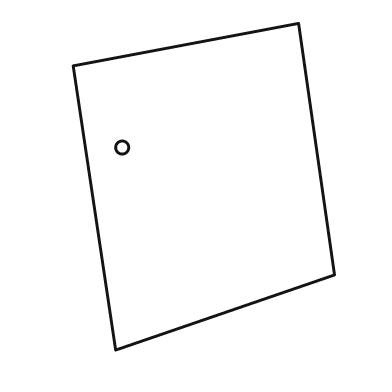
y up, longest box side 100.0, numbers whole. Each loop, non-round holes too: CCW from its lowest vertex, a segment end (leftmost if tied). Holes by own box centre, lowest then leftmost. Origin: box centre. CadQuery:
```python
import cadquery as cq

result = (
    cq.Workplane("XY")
    .moveTo(-27.0, -50.0)
    .lineTo(40.0, -27.0)
    .lineTo(29.0, 50.0)
    .lineTo(-40.0, 37.0)
    .close()
    .moveTo(-25.0, 12.0)
    .circle(2.0)
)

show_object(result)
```